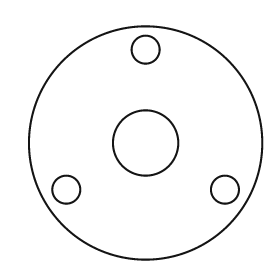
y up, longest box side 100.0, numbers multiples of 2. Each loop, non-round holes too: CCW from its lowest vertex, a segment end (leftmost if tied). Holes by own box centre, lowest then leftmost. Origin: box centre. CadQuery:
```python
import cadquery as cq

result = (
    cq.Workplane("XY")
    .moveTo(0.0, 0.0)
    .circle(50.0)
    .moveTo(-34.0, -20.0)
    .circle(6.0)
    .moveTo(34.0, -20.0)
    .circle(6.0)
    .moveTo(0.0, 0.0)
    .circle(14.0)
    .moveTo(0.0, 40.0)
    .circle(6.0)
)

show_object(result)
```